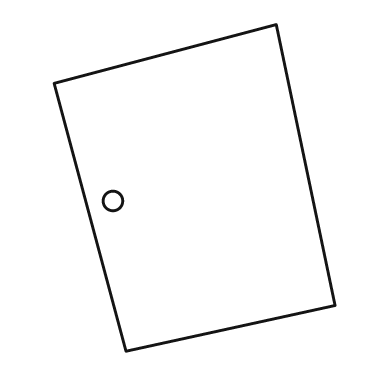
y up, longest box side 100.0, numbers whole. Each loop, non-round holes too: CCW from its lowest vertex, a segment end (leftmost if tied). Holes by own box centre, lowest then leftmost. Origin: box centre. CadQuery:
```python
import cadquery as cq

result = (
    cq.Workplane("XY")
    .moveTo(-21.0, -50.0)
    .lineTo(43.0, -36.0)
    .lineTo(25.0, 50.0)
    .lineTo(-43.0, 32.0)
    .close()
    .moveTo(-25.0, -4.0)
    .circle(3.0)
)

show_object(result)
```